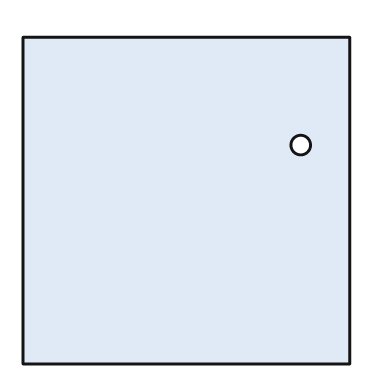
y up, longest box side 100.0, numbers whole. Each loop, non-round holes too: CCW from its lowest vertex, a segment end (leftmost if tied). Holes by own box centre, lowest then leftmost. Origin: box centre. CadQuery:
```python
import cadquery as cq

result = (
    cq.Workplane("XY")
    .moveTo(-50.0, -50.0)
    .lineTo(50.0, -50.0)
    .lineTo(50.0, 50.0)
    .lineTo(-50.0, 50.0)
    .close()
    .moveTo(35.0, 17.0)
    .circle(3.0)
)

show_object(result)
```